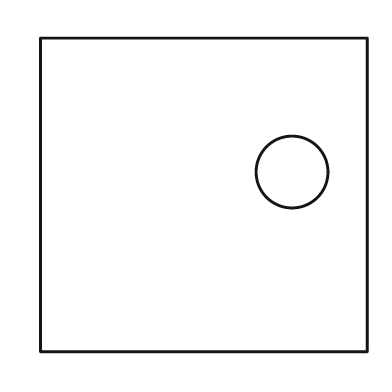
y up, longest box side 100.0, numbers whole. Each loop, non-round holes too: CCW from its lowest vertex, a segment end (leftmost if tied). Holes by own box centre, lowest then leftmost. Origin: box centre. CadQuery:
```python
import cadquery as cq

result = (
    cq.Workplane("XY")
    .moveTo(-50.0, -48.0)
    .lineTo(50.0, -48.0)
    .lineTo(50.0, 48.0)
    .lineTo(-50.0, 48.0)
    .close()
    .moveTo(27.0, 7.0)
    .circle(11.0)
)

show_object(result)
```